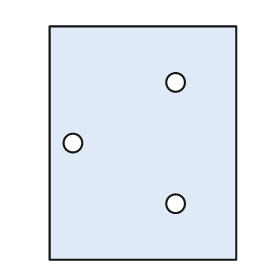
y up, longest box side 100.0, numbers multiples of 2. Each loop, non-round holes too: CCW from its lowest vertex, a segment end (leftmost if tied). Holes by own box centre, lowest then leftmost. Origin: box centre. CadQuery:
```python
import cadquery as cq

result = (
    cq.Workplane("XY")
    .moveTo(-40.0, -50.0)
    .lineTo(40.0, -50.0)
    .lineTo(40.0, 50.0)
    .lineTo(-40.0, 50.0)
    .close()
    .moveTo(14.0, -26.0)
    .circle(4.0)
    .moveTo(-30.0, 0.0)
    .circle(4.0)
    .moveTo(14.0, 26.0)
    .circle(4.0)
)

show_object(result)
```